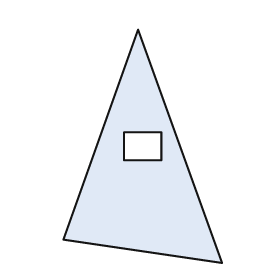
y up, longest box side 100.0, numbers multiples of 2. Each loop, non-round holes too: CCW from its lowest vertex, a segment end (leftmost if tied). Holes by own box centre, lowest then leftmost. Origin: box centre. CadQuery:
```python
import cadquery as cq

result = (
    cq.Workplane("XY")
    .moveTo(34.0, -50.0)
    .lineTo(-2.0, 50.0)
    .lineTo(-34.0, -40.0)
    .close()
    .moveTo(-8.0, -6.0)
    .lineTo(8.0, -6.0)
    .lineTo(8.0, 6.0)
    .lineTo(-8.0, 6.0)
    .close()
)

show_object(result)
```